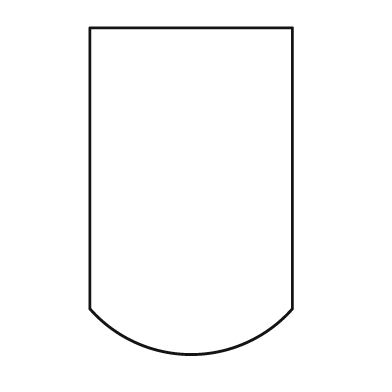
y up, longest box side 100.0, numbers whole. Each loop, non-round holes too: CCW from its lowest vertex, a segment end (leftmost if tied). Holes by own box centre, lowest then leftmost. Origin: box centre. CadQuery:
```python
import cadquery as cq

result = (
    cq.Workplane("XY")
    .moveTo(-31.0, -36.0)
    .threePointArc((0.0, -50.0), (31.0, -36.0))
    .lineTo(31.0, 50.0)
    .lineTo(-31.0, 50.0)
    .close()
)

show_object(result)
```